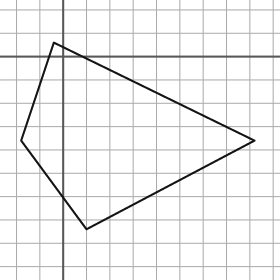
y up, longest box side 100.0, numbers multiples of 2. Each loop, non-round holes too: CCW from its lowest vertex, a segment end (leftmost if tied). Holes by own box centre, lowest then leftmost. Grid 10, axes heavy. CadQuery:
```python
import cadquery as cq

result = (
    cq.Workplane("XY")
    .moveTo(10.0, -74.0)
    .lineTo(82.0, -36.0)
    .lineTo(-4.0, 6.0)
    .lineTo(-18.0, -36.0)
    .close()
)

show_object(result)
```